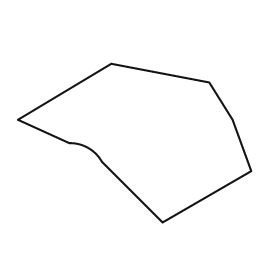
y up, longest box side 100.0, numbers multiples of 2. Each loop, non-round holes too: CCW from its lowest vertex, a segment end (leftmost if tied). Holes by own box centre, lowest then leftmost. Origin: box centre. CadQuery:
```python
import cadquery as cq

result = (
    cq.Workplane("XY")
    .moveTo(12.0, -34.0)
    .lineTo(50.0, -12.0)
    .lineTo(42.0, 10.0)
    .lineTo(32.0, 26.0)
    .lineTo(-10.0, 34.0)
    .lineTo(-50.0, 10.0)
    .lineTo(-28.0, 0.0)
    .threePointArc((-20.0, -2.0), (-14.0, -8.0))
    .close()
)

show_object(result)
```